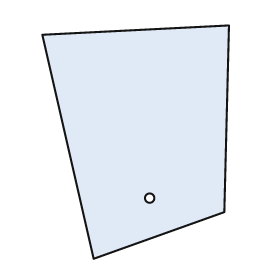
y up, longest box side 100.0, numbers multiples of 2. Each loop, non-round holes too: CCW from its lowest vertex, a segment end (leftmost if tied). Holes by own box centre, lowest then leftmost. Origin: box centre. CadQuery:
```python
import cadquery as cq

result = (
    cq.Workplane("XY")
    .moveTo(-18.0, -50.0)
    .lineTo(38.0, -30.0)
    .lineTo(40.0, 50.0)
    .lineTo(-40.0, 46.0)
    .close()
    .moveTo(6.0, -24.0)
    .circle(2.0)
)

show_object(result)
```